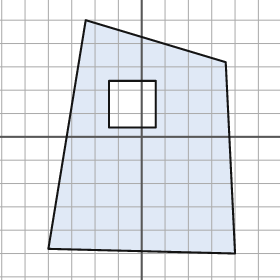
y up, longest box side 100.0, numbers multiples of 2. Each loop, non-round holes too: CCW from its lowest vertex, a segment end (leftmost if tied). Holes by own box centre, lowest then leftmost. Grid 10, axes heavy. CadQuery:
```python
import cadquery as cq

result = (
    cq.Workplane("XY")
    .moveTo(40.0, -50.0)
    .lineTo(36.0, 32.0)
    .lineTo(-24.0, 50.0)
    .lineTo(-40.0, -48.0)
    .close()
    .moveTo(-14.0, 4.0)
    .lineTo(6.0, 4.0)
    .lineTo(6.0, 24.0)
    .lineTo(-14.0, 24.0)
    .close()
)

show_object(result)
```